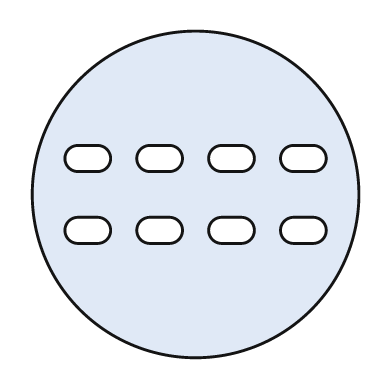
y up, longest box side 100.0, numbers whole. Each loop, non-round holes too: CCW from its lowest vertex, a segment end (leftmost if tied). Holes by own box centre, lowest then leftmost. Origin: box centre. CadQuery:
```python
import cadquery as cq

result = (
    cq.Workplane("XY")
    .moveTo(0.0, 0.0)
    .circle(50.0)
    .moveTo(-36.0, -15.0)
    .lineTo(-30.0, -15.0)
    .threePointArc((-26.0, -11.0), (-30.0, -7.0))
    .lineTo(-36.0, -7.0)
    .threePointArc((-40.0, -11.0), (-36.0, -15.0))
    .close()
    .moveTo(-14.0, -15.0)
    .lineTo(-8.0, -15.0)
    .threePointArc((-4.0, -11.0), (-8.0, -7.0))
    .lineTo(-14.0, -7.0)
    .threePointArc((-18.0, -11.0), (-14.0, -15.0))
    .close()
    .moveTo(8.0, -15.0)
    .lineTo(14.0, -15.0)
    .threePointArc((18.0, -11.0), (14.0, -7.0))
    .lineTo(8.0, -7.0)
    .threePointArc((4.0, -11.0), (8.0, -15.0))
    .close()
    .moveTo(30.0, -15.0)
    .lineTo(36.0, -15.0)
    .threePointArc((40.0, -11.0), (36.0, -7.0))
    .lineTo(30.0, -7.0)
    .threePointArc((26.0, -11.0), (30.0, -15.0))
    .close()
    .moveTo(-36.0, 7.0)
    .lineTo(-30.0, 7.0)
    .threePointArc((-26.0, 11.0), (-30.0, 15.0))
    .lineTo(-36.0, 15.0)
    .threePointArc((-40.0, 11.0), (-36.0, 7.0))
    .close()
    .moveTo(-14.0, 7.0)
    .lineTo(-8.0, 7.0)
    .threePointArc((-4.0, 11.0), (-8.0, 15.0))
    .lineTo(-14.0, 15.0)
    .threePointArc((-18.0, 11.0), (-14.0, 7.0))
    .close()
    .moveTo(8.0, 7.0)
    .lineTo(14.0, 7.0)
    .threePointArc((18.0, 11.0), (14.0, 15.0))
    .lineTo(8.0, 15.0)
    .threePointArc((4.0, 11.0), (8.0, 7.0))
    .close()
    .moveTo(30.0, 7.0)
    .lineTo(36.0, 7.0)
    .threePointArc((40.0, 11.0), (36.0, 15.0))
    .lineTo(30.0, 15.0)
    .threePointArc((26.0, 11.0), (30.0, 7.0))
    .close()
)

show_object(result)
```